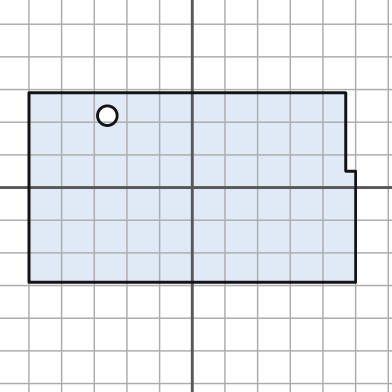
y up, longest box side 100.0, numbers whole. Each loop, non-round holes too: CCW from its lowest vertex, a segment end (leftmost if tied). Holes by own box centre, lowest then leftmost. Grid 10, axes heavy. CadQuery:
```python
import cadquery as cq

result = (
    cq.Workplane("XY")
    .moveTo(-50.0, -29.0)
    .lineTo(50.0, -29.0)
    .lineTo(50.0, 5.0)
    .lineTo(47.0, 5.0)
    .lineTo(47.0, 29.0)
    .lineTo(-50.0, 29.0)
    .close()
    .moveTo(-26.0, 22.0)
    .circle(3.0)
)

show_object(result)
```